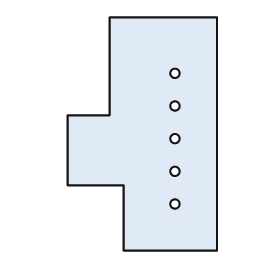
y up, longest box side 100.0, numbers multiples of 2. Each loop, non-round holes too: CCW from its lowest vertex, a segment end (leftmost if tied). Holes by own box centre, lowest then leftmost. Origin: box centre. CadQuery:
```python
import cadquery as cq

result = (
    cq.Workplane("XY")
    .moveTo(-8.0, -50.0)
    .lineTo(32.0, -50.0)
    .lineTo(32.0, 50.0)
    .lineTo(-14.0, 50.0)
    .lineTo(-14.0, 8.0)
    .lineTo(-32.0, 8.0)
    .lineTo(-32.0, -22.0)
    .lineTo(-8.0, -22.0)
    .close()
    .moveTo(14.0, -30.0)
    .circle(2.0)
    .moveTo(14.0, -16.0)
    .circle(2.0)
    .moveTo(14.0, -2.0)
    .circle(2.0)
    .moveTo(14.0, 12.0)
    .circle(2.0)
    .moveTo(14.0, 26.0)
    .circle(2.0)
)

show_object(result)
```